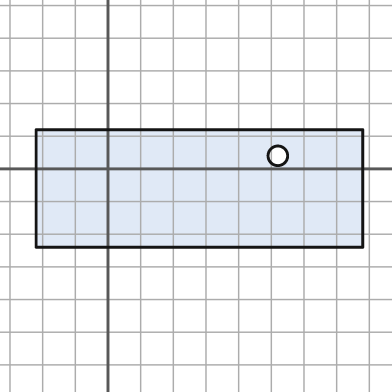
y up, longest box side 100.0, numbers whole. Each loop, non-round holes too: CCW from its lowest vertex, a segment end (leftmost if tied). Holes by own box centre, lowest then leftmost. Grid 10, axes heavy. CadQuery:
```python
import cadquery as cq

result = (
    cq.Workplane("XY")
    .moveTo(-22.0, -24.0)
    .lineTo(78.0, -24.0)
    .lineTo(78.0, 12.0)
    .lineTo(-22.0, 12.0)
    .close()
    .moveTo(52.0, 4.0)
    .circle(3.0)
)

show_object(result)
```